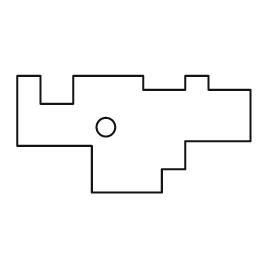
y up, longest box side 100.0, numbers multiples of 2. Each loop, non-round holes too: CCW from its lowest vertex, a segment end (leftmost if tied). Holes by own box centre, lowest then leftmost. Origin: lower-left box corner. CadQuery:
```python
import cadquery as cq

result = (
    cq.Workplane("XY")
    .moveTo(32.0, 0.0)
    .lineTo(62.0, 0.0)
    .lineTo(62.0, 10.0)
    .lineTo(72.0, 10.0)
    .lineTo(72.0, 22.0)
    .lineTo(100.0, 22.0)
    .lineTo(100.0, 44.0)
    .lineTo(82.0, 44.0)
    .lineTo(82.0, 50.0)
    .lineTo(72.0, 50.0)
    .lineTo(72.0, 44.0)
    .lineTo(54.0, 44.0)
    .lineTo(54.0, 50.0)
    .lineTo(24.0, 50.0)
    .lineTo(24.0, 38.0)
    .lineTo(10.0, 38.0)
    .lineTo(10.0, 50.0)
    .lineTo(0.0, 50.0)
    .lineTo(0.0, 20.0)
    .lineTo(32.0, 20.0)
    .close()
    .moveTo(38.0, 28.0)
    .circle(4.0)
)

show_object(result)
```